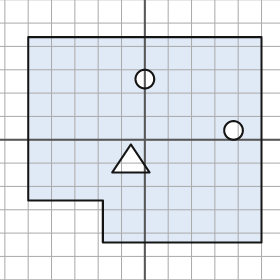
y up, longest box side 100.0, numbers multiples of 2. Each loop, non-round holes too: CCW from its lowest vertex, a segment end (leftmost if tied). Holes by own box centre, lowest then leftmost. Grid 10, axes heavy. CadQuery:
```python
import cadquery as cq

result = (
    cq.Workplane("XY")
    .moveTo(-18.0, -44.0)
    .lineTo(50.0, -44.0)
    .lineTo(50.0, 44.0)
    .lineTo(-50.0, 44.0)
    .lineTo(-50.0, -26.0)
    .lineTo(-18.0, -26.0)
    .close()
    .moveTo(-14.0, -14.0)
    .lineTo(2.0, -14.0)
    .lineTo(-6.0, -2.0)
    .close()
    .moveTo(38.0, 4.0)
    .circle(4.0)
    .moveTo(0.0, 26.0)
    .circle(4.0)
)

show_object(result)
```